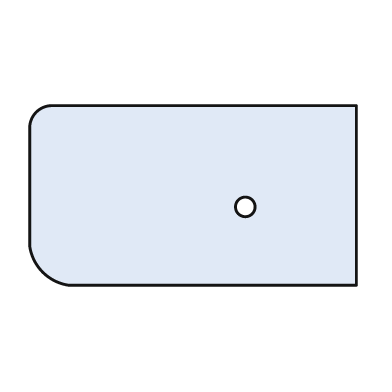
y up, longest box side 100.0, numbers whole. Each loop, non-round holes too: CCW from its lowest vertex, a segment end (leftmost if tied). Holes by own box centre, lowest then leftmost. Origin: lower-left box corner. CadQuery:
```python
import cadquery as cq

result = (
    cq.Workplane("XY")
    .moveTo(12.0, 0.0)
    .lineTo(100.0, 0.0)
    .lineTo(100.0, 55.0)
    .lineTo(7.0, 55.0)
    .threePointArc((2.0, 53.0), (0.0, 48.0))
    .lineTo(0.0, 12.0)
    .threePointArc((4.0, 4.0), (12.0, 0.0))
    .close()
    .moveTo(66.0, 24.0)
    .circle(3.0)
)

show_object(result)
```